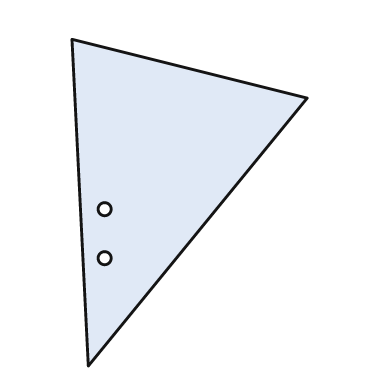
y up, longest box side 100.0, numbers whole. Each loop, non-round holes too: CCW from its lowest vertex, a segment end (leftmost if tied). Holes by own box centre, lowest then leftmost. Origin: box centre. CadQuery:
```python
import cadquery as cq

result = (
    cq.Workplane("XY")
    .moveTo(-31.0, -50.0)
    .lineTo(36.0, 32.0)
    .lineTo(-36.0, 50.0)
    .close()
    .moveTo(-26.0, -17.0)
    .circle(2.0)
    .moveTo(-26.0, -2.0)
    .circle(2.0)
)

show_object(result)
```